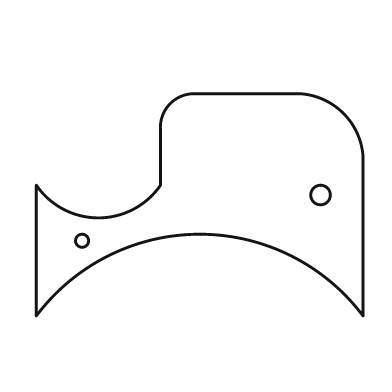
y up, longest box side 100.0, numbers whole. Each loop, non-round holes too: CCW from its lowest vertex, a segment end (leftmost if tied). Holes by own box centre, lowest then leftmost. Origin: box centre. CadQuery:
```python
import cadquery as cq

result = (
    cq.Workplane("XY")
    .moveTo(-50.0, -34.0)
    .threePointArc((0.0, -9.0), (50.0, -34.0))
    .lineTo(50.0, 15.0)
    .threePointArc((44.0, 28.0), (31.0, 34.0))
    .lineTo(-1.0, 34.0)
    .threePointArc((-9.0, 31.0), (-12.0, 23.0))
    .lineTo(-12.0, 6.0)
    .threePointArc((-31.0, -4.0), (-50.0, 6.0))
    .close()
    .moveTo(-36.0, -11.0)
    .circle(2.0)
    .moveTo(37.0, 3.0)
    .circle(3.0)
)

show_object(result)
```